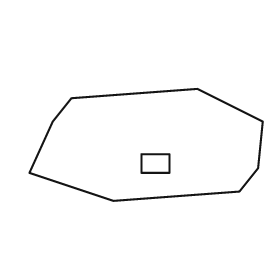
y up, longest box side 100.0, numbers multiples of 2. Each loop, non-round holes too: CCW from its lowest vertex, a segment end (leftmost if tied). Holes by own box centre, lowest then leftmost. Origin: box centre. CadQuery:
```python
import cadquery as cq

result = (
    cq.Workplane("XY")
    .moveTo(-14.0, -24.0)
    .lineTo(40.0, -20.0)
    .lineTo(48.0, -10.0)
    .lineTo(50.0, 10.0)
    .lineTo(22.0, 24.0)
    .lineTo(-32.0, 20.0)
    .lineTo(-40.0, 10.0)
    .lineTo(-50.0, -12.0)
    .close()
    .moveTo(-2.0, -12.0)
    .lineTo(10.0, -12.0)
    .lineTo(10.0, -4.0)
    .lineTo(-2.0, -4.0)
    .close()
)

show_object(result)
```